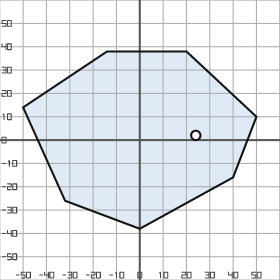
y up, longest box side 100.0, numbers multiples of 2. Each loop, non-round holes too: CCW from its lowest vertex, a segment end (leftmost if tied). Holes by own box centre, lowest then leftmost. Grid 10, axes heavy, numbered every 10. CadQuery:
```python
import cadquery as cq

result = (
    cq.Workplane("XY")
    .moveTo(0.0, -38.0)
    .lineTo(40.0, -16.0)
    .lineTo(50.0, 10.0)
    .lineTo(20.0, 38.0)
    .lineTo(-14.0, 38.0)
    .lineTo(-50.0, 14.0)
    .lineTo(-32.0, -26.0)
    .close()
    .moveTo(24.0, 2.0)
    .circle(2.0)
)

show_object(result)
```